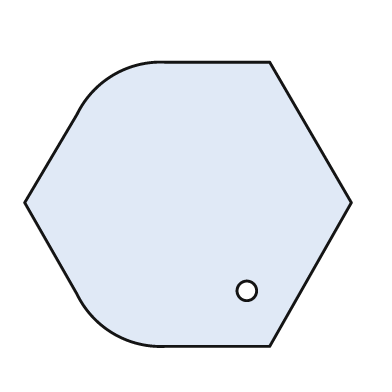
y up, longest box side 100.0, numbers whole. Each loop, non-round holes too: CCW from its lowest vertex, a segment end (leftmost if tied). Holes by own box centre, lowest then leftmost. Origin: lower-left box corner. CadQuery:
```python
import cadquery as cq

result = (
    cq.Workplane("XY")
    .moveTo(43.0, 0.0)
    .lineTo(75.0, 0.0)
    .lineTo(100.0, 44.0)
    .lineTo(75.0, 87.0)
    .lineTo(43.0, 87.0)
    .threePointArc((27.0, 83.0), (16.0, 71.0))
    .lineTo(0.0, 44.0)
    .lineTo(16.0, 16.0)
    .threePointArc((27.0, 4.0), (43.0, 0.0))
    .close()
    .moveTo(68.0, 17.0)
    .circle(3.0)
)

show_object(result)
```